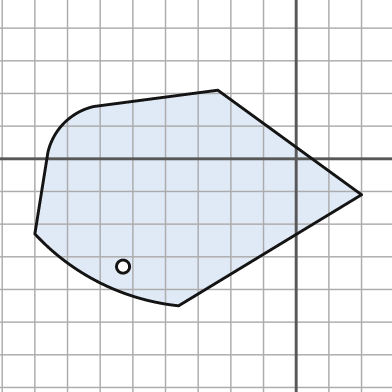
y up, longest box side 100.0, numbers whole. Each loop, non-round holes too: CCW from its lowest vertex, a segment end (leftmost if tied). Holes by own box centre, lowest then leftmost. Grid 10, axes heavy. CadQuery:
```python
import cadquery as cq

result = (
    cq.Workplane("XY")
    .moveTo(-36.0, -45.0)
    .lineTo(20.0, -11.0)
    .lineTo(-24.0, 21.0)
    .lineTo(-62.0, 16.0)
    .threePointArc((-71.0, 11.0), (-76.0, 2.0))
    .lineTo(-80.0, -23.0)
    .threePointArc((-60.0, -38.0), (-36.0, -45.0))
    .close()
    .moveTo(-53.0, -33.0)
    .circle(2.0)
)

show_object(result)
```